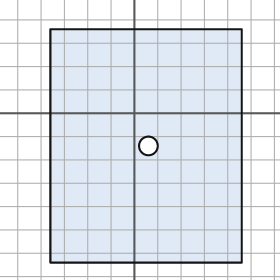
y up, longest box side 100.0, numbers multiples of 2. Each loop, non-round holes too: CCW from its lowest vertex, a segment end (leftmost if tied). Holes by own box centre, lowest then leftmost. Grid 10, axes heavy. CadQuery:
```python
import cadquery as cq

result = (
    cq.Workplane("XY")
    .moveTo(-36.0, -64.0)
    .lineTo(46.0, -64.0)
    .lineTo(46.0, 36.0)
    .lineTo(-36.0, 36.0)
    .close()
    .moveTo(6.0, -14.0)
    .circle(4.0)
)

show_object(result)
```